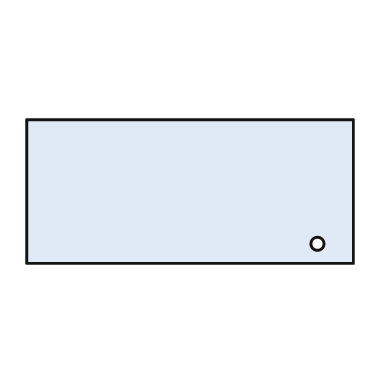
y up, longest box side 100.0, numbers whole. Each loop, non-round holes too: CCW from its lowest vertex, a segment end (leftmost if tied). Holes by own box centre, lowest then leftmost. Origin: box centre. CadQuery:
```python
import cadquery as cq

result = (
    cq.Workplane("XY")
    .moveTo(-50.0, -22.0)
    .lineTo(50.0, -22.0)
    .lineTo(50.0, 22.0)
    .lineTo(-50.0, 22.0)
    .close()
    .moveTo(39.0, -16.0)
    .circle(2.0)
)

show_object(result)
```